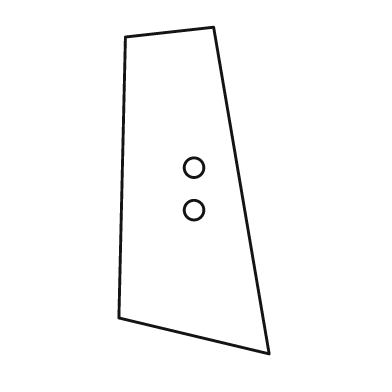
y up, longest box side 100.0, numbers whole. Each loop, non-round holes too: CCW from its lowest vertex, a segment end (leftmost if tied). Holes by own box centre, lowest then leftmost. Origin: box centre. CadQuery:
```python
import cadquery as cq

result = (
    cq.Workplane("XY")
    .moveTo(23.0, -50.0)
    .lineTo(6.0, 50.0)
    .lineTo(-21.0, 47.0)
    .lineTo(-23.0, -39.0)
    .close()
    .moveTo(0.0, -6.0)
    .circle(3.0)
    .moveTo(0.0, 7.0)
    .circle(3.0)
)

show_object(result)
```